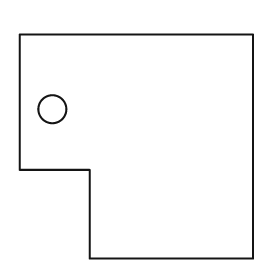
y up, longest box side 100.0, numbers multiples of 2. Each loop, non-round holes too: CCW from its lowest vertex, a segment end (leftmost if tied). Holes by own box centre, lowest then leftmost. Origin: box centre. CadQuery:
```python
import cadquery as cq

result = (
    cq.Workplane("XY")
    .moveTo(-20.0, -48.0)
    .lineTo(50.0, -48.0)
    .lineTo(50.0, 48.0)
    .lineTo(-50.0, 48.0)
    .lineTo(-50.0, -10.0)
    .lineTo(-20.0, -10.0)
    .close()
    .moveTo(-36.0, 16.0)
    .circle(6.0)
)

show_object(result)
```